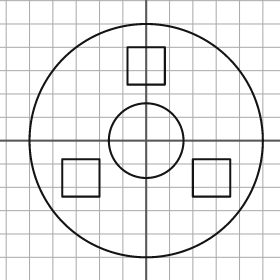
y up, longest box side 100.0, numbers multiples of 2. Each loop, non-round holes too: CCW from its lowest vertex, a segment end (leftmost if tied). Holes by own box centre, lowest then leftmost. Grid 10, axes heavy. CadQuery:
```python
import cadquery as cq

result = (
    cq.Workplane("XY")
    .moveTo(0.0, 0.0)
    .circle(50.0)
    .moveTo(-36.0, -24.0)
    .lineTo(-20.0, -24.0)
    .lineTo(-20.0, -8.0)
    .lineTo(-36.0, -8.0)
    .close()
    .moveTo(20.0, -24.0)
    .lineTo(36.0, -24.0)
    .lineTo(36.0, -8.0)
    .lineTo(20.0, -8.0)
    .close()
    .moveTo(0.0, 0.0)
    .circle(16.0)
    .moveTo(-8.0, 24.0)
    .lineTo(8.0, 24.0)
    .lineTo(8.0, 40.0)
    .lineTo(-8.0, 40.0)
    .close()
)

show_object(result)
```